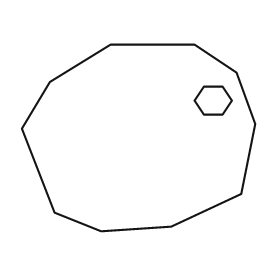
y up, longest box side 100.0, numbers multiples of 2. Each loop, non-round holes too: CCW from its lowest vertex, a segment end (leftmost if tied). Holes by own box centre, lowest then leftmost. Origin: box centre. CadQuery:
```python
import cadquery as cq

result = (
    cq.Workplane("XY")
    .moveTo(-16.0, -40.0)
    .lineTo(14.0, -38.0)
    .lineTo(44.0, -24.0)
    .lineTo(50.0, 6.0)
    .lineTo(42.0, 28.0)
    .lineTo(24.0, 40.0)
    .lineTo(-12.0, 40.0)
    .lineTo(-38.0, 24.0)
    .lineTo(-50.0, 4.0)
    .lineTo(-36.0, -32.0)
    .close()
    .moveTo(28.0, 10.0)
    .lineTo(36.0, 10.0)
    .lineTo(40.0, 16.0)
    .lineTo(36.0, 22.0)
    .lineTo(28.0, 22.0)
    .lineTo(24.0, 16.0)
    .close()
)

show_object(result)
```